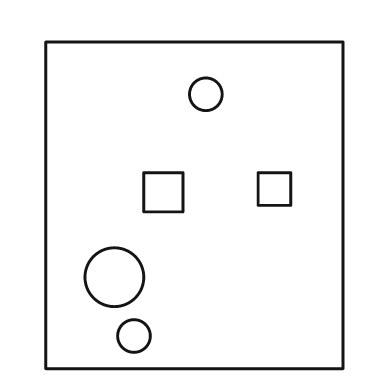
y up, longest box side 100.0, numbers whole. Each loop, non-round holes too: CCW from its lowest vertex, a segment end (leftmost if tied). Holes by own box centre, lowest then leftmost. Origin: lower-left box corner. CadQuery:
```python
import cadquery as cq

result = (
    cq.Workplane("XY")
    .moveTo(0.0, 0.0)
    .lineTo(91.0, 0.0)
    .lineTo(91.0, 100.0)
    .lineTo(0.0, 100.0)
    .close()
    .moveTo(27.0, 10.0)
    .circle(5.0)
    .moveTo(21.0, 28.0)
    .circle(9.0)
    .moveTo(30.0, 48.0)
    .lineTo(42.0, 48.0)
    .lineTo(42.0, 60.0)
    .lineTo(30.0, 60.0)
    .close()
    .moveTo(65.0, 50.0)
    .lineTo(75.0, 50.0)
    .lineTo(75.0, 60.0)
    .lineTo(65.0, 60.0)
    .close()
    .moveTo(49.0, 84.0)
    .circle(5.0)
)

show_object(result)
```